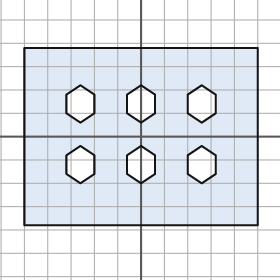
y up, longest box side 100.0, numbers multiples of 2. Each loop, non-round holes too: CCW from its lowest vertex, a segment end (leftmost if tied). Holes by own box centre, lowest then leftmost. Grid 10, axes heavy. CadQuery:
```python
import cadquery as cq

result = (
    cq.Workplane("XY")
    .moveTo(-50.0, -38.0)
    .lineTo(50.0, -38.0)
    .lineTo(50.0, 38.0)
    .lineTo(-50.0, 38.0)
    .close()
    .moveTo(-26.0, -20.0)
    .lineTo(-20.0, -16.0)
    .lineTo(-20.0, -8.0)
    .lineTo(-26.0, -4.0)
    .lineTo(-32.0, -8.0)
    .lineTo(-32.0, -16.0)
    .close()
    .moveTo(0.0, -20.0)
    .lineTo(6.0, -16.0)
    .lineTo(6.0, -8.0)
    .lineTo(0.0, -4.0)
    .lineTo(-6.0, -8.0)
    .lineTo(-6.0, -16.0)
    .close()
    .moveTo(26.0, -20.0)
    .lineTo(32.0, -16.0)
    .lineTo(32.0, -8.0)
    .lineTo(26.0, -4.0)
    .lineTo(20.0, -8.0)
    .lineTo(20.0, -16.0)
    .close()
    .moveTo(-26.0, 6.0)
    .lineTo(-20.0, 10.0)
    .lineTo(-20.0, 18.0)
    .lineTo(-26.0, 22.0)
    .lineTo(-32.0, 18.0)
    .lineTo(-32.0, 10.0)
    .close()
    .moveTo(0.0, 6.0)
    .lineTo(6.0, 10.0)
    .lineTo(6.0, 18.0)
    .lineTo(0.0, 22.0)
    .lineTo(-6.0, 18.0)
    .lineTo(-6.0, 10.0)
    .close()
    .moveTo(26.0, 6.0)
    .lineTo(32.0, 10.0)
    .lineTo(32.0, 18.0)
    .lineTo(26.0, 22.0)
    .lineTo(20.0, 18.0)
    .lineTo(20.0, 10.0)
    .close()
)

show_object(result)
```